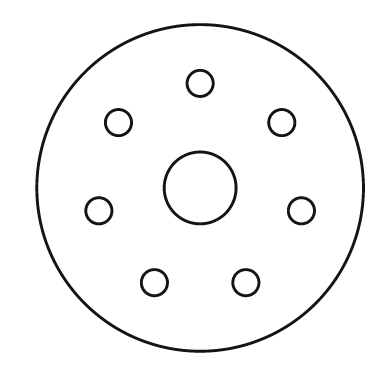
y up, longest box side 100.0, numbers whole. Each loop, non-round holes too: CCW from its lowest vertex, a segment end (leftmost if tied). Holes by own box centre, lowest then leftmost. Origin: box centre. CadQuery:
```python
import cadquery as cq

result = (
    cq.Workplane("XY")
    .moveTo(0.0, 0.0)
    .circle(50.0)
    .moveTo(-14.0, -29.0)
    .circle(4.0)
    .moveTo(14.0, -29.0)
    .circle(4.0)
    .moveTo(-31.0, -7.0)
    .circle(4.0)
    .moveTo(31.0, -7.0)
    .circle(4.0)
    .moveTo(0.0, 0.0)
    .circle(11.0)
    .moveTo(-25.0, 20.0)
    .circle(4.0)
    .moveTo(25.0, 20.0)
    .circle(4.0)
    .moveTo(0.0, 32.0)
    .circle(4.0)
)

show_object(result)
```